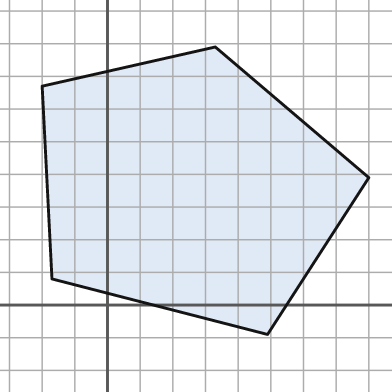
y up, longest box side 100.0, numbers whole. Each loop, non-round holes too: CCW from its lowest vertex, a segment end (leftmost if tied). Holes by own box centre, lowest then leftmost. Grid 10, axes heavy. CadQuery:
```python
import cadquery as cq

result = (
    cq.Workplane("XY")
    .moveTo(49.0, -9.0)
    .lineTo(80.0, 39.0)
    .lineTo(33.0, 79.0)
    .lineTo(-20.0, 67.0)
    .lineTo(-17.0, 8.0)
    .close()
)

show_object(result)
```